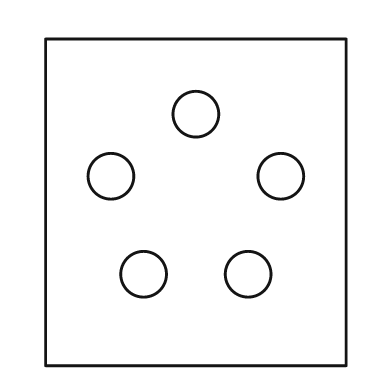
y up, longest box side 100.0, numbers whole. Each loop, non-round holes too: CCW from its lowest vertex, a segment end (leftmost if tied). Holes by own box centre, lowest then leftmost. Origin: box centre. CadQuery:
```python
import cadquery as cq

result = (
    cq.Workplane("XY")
    .moveTo(-46.0, -50.0)
    .lineTo(46.0, -50.0)
    .lineTo(46.0, 50.0)
    .lineTo(-46.0, 50.0)
    .close()
    .moveTo(-16.0, -22.0)
    .circle(7.0)
    .moveTo(16.0, -22.0)
    .circle(7.0)
    .moveTo(-26.0, 8.0)
    .circle(7.0)
    .moveTo(26.0, 8.0)
    .circle(7.0)
    .moveTo(0.0, 27.0)
    .circle(7.0)
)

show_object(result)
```